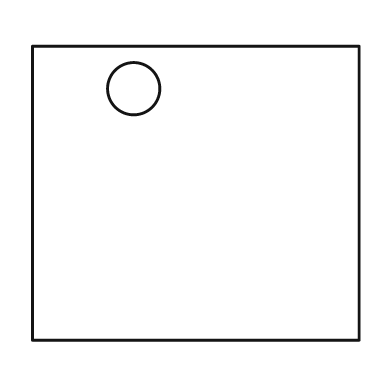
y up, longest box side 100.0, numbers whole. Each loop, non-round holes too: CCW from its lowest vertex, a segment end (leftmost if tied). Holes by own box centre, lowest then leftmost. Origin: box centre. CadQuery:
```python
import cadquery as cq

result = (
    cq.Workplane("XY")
    .moveTo(-50.0, -45.0)
    .lineTo(50.0, -45.0)
    .lineTo(50.0, 45.0)
    .lineTo(-50.0, 45.0)
    .close()
    .moveTo(-19.0, 32.0)
    .circle(8.0)
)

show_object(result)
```